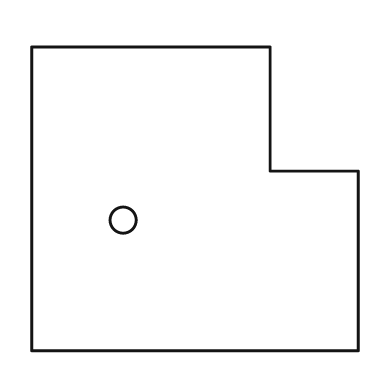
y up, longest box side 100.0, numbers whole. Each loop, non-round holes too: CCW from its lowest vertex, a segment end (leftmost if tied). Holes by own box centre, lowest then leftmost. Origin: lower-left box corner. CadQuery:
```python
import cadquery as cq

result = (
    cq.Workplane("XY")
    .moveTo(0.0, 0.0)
    .lineTo(100.0, 0.0)
    .lineTo(100.0, 55.0)
    .lineTo(73.0, 55.0)
    .lineTo(73.0, 93.0)
    .lineTo(0.0, 93.0)
    .close()
    .moveTo(28.0, 40.0)
    .circle(4.0)
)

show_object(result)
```